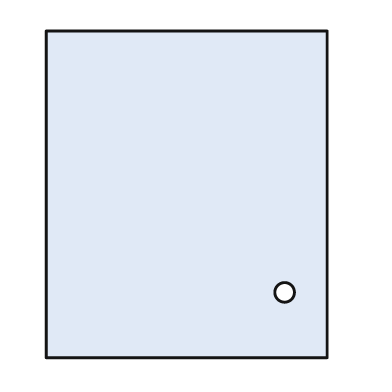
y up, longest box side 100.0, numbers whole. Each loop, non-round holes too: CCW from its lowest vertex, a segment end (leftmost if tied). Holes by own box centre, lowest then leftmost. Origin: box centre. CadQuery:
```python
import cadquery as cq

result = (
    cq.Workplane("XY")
    .moveTo(-43.0, -50.0)
    .lineTo(43.0, -50.0)
    .lineTo(43.0, 50.0)
    .lineTo(-43.0, 50.0)
    .close()
    .moveTo(30.0, -30.0)
    .circle(3.0)
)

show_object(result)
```